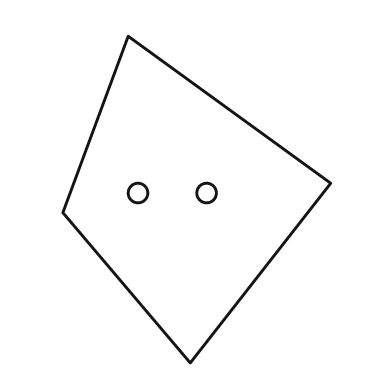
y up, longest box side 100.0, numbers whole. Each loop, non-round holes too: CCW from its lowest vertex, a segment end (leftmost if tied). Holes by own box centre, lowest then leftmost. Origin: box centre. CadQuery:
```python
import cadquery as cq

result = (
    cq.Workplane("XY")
    .moveTo(-2.0, -50.0)
    .lineTo(41.0, 5.0)
    .lineTo(-21.0, 50.0)
    .lineTo(-41.0, -4.0)
    .close()
    .moveTo(-18.0, 2.0)
    .circle(3.0)
    .moveTo(3.0, 2.0)
    .circle(3.0)
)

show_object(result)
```